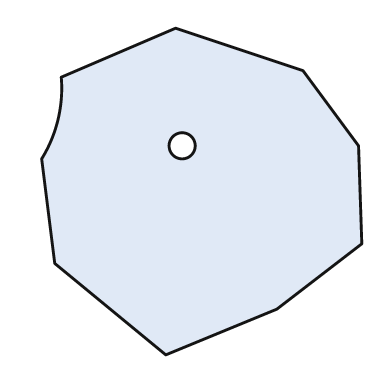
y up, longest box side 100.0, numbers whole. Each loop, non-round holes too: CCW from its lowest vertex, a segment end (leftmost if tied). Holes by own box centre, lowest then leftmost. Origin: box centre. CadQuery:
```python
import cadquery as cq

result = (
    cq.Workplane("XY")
    .moveTo(-11.0, -50.0)
    .lineTo(23.0, -36.0)
    .lineTo(49.0, -16.0)
    .lineTo(48.0, 14.0)
    .lineTo(31.0, 37.0)
    .lineTo(-8.0, 50.0)
    .lineTo(-43.0, 35.0)
    .threePointArc((-44.0, 22.0), (-49.0, 10.0))
    .lineTo(-45.0, -22.0)
    .close()
    .moveTo(-6.0, 14.0)
    .circle(4.0)
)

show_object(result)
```